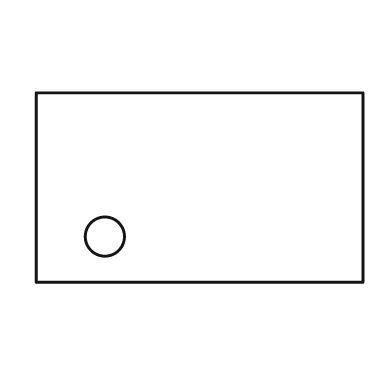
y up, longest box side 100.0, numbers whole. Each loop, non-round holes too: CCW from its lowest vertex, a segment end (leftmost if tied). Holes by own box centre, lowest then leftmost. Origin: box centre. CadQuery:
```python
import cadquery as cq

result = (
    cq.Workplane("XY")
    .moveTo(-50.0, -29.0)
    .lineTo(50.0, -29.0)
    .lineTo(50.0, 29.0)
    .lineTo(-50.0, 29.0)
    .close()
    .moveTo(-29.0, -15.0)
    .circle(6.0)
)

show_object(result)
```